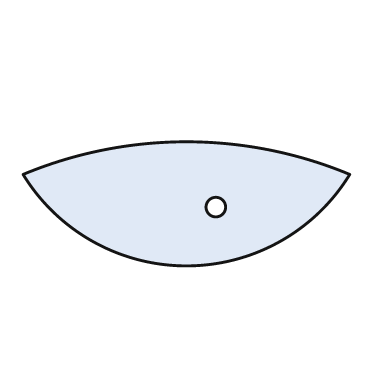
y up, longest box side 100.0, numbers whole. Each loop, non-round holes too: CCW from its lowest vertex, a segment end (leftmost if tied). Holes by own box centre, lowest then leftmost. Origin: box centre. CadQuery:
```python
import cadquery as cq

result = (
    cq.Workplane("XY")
    .moveTo(-50.0, 9.0)
    .threePointArc((0.0, -19.0), (50.0, 9.0))
    .threePointArc((0.0, 19.0), (-50.0, 9.0))
    .close()
    .moveTo(9.0, -1.0)
    .circle(3.0)
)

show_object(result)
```